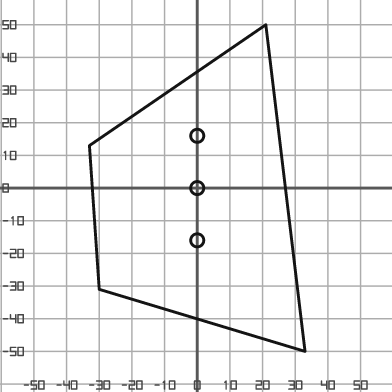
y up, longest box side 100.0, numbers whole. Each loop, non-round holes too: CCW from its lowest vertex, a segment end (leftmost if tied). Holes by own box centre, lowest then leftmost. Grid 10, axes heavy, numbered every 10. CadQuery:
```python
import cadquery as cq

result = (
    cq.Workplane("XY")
    .moveTo(33.0, -50.0)
    .lineTo(21.0, 50.0)
    .lineTo(-33.0, 13.0)
    .lineTo(-30.0, -31.0)
    .close()
    .moveTo(0.0, -16.0)
    .circle(2.0)
    .moveTo(0.0, 0.0)
    .circle(2.0)
    .moveTo(0.0, 16.0)
    .circle(2.0)
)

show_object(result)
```